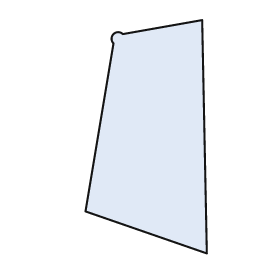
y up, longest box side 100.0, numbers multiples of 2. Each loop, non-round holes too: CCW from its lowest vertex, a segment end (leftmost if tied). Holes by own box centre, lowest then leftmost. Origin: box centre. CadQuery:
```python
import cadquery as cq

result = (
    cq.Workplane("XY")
    .moveTo(26.0, -50.0)
    .lineTo(24.0, 50.0)
    .lineTo(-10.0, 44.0)
    .threePointArc((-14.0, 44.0), (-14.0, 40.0))
    .lineTo(-26.0, -32.0)
    .close()
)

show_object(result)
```